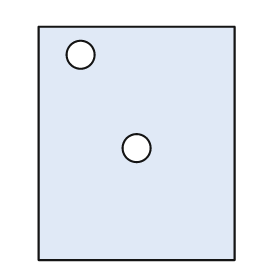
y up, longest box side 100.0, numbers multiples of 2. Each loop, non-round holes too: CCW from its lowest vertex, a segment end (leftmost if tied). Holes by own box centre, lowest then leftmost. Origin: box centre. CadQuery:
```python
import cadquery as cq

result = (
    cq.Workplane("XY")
    .moveTo(-42.0, -50.0)
    .lineTo(42.0, -50.0)
    .lineTo(42.0, 50.0)
    .lineTo(-42.0, 50.0)
    .close()
    .moveTo(0.0, -2.0)
    .circle(6.0)
    .moveTo(-24.0, 38.0)
    .circle(6.0)
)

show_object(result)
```